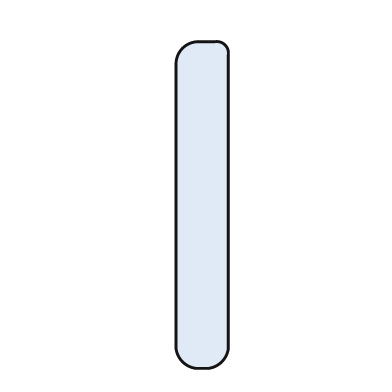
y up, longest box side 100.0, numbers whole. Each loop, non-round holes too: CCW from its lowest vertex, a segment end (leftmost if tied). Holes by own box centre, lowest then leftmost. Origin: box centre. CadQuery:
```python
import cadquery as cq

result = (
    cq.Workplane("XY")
    .moveTo(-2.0, -50.0)
    .lineTo(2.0, -50.0)
    .threePointArc((6.0, -48.0), (8.0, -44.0))
    .lineTo(8.0, 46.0)
    .threePointArc((7.0, 49.0), (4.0, 50.0))
    .lineTo(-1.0, 50.0)
    .threePointArc((-6.0, 48.0), (-8.0, 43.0))
    .lineTo(-8.0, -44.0)
    .threePointArc((-6.0, -48.0), (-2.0, -50.0))
    .close()
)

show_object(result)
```